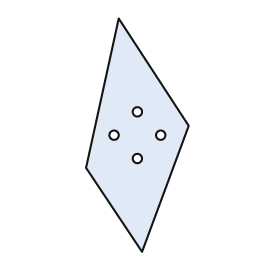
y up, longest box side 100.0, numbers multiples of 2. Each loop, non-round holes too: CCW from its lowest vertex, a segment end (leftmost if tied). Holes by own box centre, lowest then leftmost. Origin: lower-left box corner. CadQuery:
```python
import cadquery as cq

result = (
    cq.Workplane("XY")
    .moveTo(24.0, 0.0)
    .lineTo(44.0, 54.0)
    .lineTo(14.0, 100.0)
    .lineTo(0.0, 36.0)
    .close()
    .moveTo(22.0, 40.0)
    .circle(2.0)
    .moveTo(12.0, 50.0)
    .circle(2.0)
    .moveTo(32.0, 50.0)
    .circle(2.0)
    .moveTo(22.0, 60.0)
    .circle(2.0)
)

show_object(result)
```